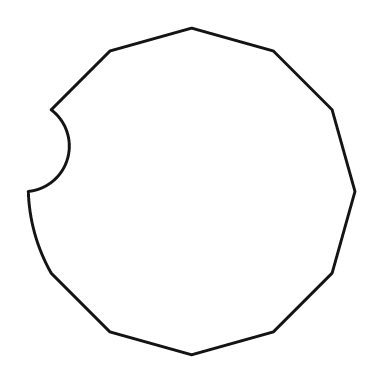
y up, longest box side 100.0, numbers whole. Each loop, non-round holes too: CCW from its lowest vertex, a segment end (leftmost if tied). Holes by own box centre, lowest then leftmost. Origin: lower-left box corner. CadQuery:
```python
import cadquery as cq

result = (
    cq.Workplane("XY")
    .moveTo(50.0, 0.0)
    .lineTo(75.0, 7.0)
    .lineTo(93.0, 25.0)
    .lineTo(100.0, 50.0)
    .lineTo(93.0, 75.0)
    .lineTo(75.0, 93.0)
    .lineTo(50.0, 100.0)
    .lineTo(25.0, 93.0)
    .lineTo(7.0, 75.0)
    .threePointArc((12.0, 60.0), (0.0, 50.0))
    .threePointArc((2.0, 37.0), (7.0, 25.0))
    .lineTo(25.0, 7.0)
    .close()
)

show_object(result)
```